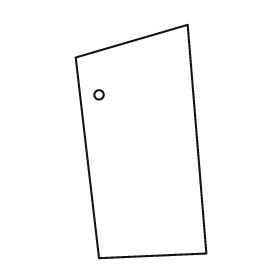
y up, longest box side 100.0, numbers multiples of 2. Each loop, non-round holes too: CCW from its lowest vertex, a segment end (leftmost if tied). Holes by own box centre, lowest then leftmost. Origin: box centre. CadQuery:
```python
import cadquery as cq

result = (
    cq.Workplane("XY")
    .moveTo(-18.0, -50.0)
    .lineTo(28.0, -48.0)
    .lineTo(20.0, 50.0)
    .lineTo(-28.0, 36.0)
    .close()
    .moveTo(-18.0, 20.0)
    .circle(2.0)
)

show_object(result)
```